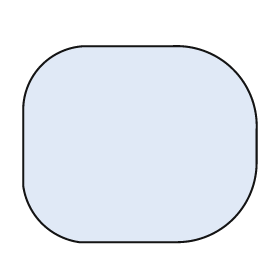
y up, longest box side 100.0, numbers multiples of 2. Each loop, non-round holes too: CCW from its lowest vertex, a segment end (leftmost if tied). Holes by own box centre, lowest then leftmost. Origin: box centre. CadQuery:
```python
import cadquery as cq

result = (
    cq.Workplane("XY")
    .moveTo(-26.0, -42.0)
    .lineTo(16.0, -42.0)
    .threePointArc((40.0, -32.0), (50.0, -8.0))
    .lineTo(50.0, 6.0)
    .threePointArc((40.0, 32.0), (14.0, 42.0))
    .lineTo(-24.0, 42.0)
    .threePointArc((-42.0, 34.0), (-50.0, 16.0))
    .lineTo(-50.0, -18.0)
    .threePointArc((-42.0, -34.0), (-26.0, -42.0))
    .close()
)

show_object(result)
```